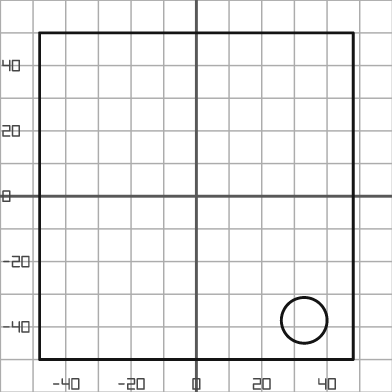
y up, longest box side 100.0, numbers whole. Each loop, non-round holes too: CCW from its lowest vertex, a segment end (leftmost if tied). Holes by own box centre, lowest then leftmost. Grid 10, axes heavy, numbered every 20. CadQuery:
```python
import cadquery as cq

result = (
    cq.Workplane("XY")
    .moveTo(-48.0, -50.0)
    .lineTo(48.0, -50.0)
    .lineTo(48.0, 50.0)
    .lineTo(-48.0, 50.0)
    .close()
    .moveTo(33.0, -38.0)
    .circle(7.0)
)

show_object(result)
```